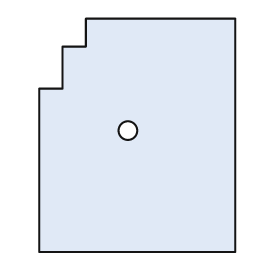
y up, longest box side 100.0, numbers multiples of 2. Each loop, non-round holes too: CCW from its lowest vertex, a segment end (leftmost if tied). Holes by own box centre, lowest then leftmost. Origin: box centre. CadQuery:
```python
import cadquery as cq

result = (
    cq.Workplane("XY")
    .moveTo(-42.0, -50.0)
    .lineTo(42.0, -50.0)
    .lineTo(42.0, 50.0)
    .lineTo(-22.0, 50.0)
    .lineTo(-22.0, 38.0)
    .lineTo(-32.0, 38.0)
    .lineTo(-32.0, 20.0)
    .lineTo(-42.0, 20.0)
    .close()
    .moveTo(-4.0, 2.0)
    .circle(4.0)
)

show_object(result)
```